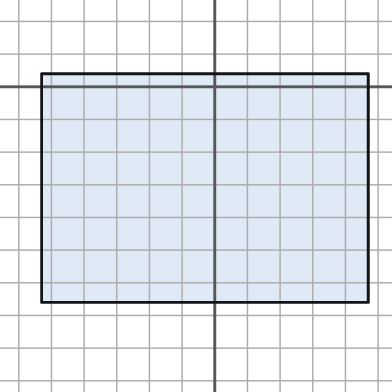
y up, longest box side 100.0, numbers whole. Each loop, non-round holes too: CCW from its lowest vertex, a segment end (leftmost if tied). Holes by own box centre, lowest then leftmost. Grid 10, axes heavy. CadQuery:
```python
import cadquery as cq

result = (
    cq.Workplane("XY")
    .moveTo(-53.0, -66.0)
    .lineTo(47.0, -66.0)
    .lineTo(47.0, 4.0)
    .lineTo(-53.0, 4.0)
    .close()
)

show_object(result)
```